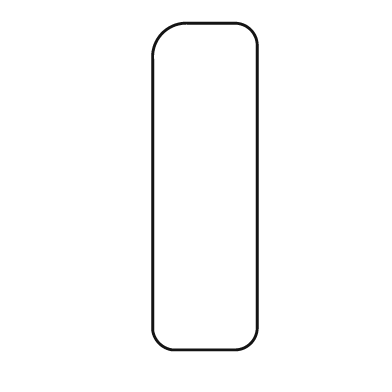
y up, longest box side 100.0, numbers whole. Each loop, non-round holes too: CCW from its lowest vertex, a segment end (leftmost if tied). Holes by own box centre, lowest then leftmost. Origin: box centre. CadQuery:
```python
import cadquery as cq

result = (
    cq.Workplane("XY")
    .moveTo(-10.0, -50.0)
    .lineTo(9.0, -50.0)
    .threePointArc((14.0, -48.0), (16.0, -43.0))
    .lineTo(16.0, 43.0)
    .threePointArc((14.0, 48.0), (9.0, 50.0))
    .lineTo(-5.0, 50.0)
    .threePointArc((-13.0, 47.0), (-16.0, 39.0))
    .lineTo(-16.0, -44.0)
    .threePointArc((-14.0, -48.0), (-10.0, -50.0))
    .close()
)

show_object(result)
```